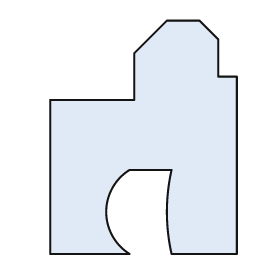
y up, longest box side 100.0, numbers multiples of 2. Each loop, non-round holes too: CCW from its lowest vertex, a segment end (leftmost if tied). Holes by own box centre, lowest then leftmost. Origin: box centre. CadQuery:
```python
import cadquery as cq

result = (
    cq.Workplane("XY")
    .moveTo(-40.0, -50.0)
    .lineTo(-6.0, -50.0)
    .threePointArc((-16.0, -32.0), (-6.0, -14.0))
    .lineTo(12.0, -14.0)
    .threePointArc((10.0, -32.0), (12.0, -50.0))
    .lineTo(40.0, -50.0)
    .lineTo(40.0, 26.0)
    .lineTo(32.0, 26.0)
    .lineTo(32.0, 42.0)
    .lineTo(24.0, 50.0)
    .lineTo(10.0, 50.0)
    .lineTo(-4.0, 36.0)
    .lineTo(-4.0, 16.0)
    .lineTo(-40.0, 16.0)
    .close()
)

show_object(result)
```